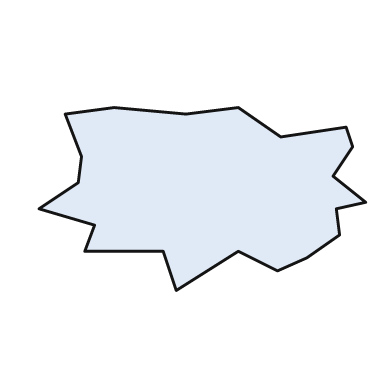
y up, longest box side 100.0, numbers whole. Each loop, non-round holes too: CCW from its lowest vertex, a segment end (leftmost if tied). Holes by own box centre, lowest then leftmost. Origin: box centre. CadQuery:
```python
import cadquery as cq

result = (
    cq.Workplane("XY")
    .moveTo(-8.0, -28.0)
    .lineTo(11.0, -16.0)
    .lineTo(23.0, -22.0)
    .lineTo(32.0, -18.0)
    .lineTo(42.0, -11.0)
    .lineTo(41.0, -3.0)
    .lineTo(50.0, -1.0)
    .lineTo(40.0, 7.0)
    .lineTo(46.0, 16.0)
    .lineTo(44.0, 22.0)
    .lineTo(24.0, 19.0)
    .lineTo(11.0, 28.0)
    .lineTo(-5.0, 26.0)
    .lineTo(-27.0, 28.0)
    .lineTo(-42.0, 26.0)
    .lineTo(-37.0, 13.0)
    .lineTo(-38.0, 5.0)
    .lineTo(-50.0, -3.0)
    .lineTo(-33.0, -8.0)
    .lineTo(-36.0, -16.0)
    .lineTo(-12.0, -16.0)
    .close()
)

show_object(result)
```